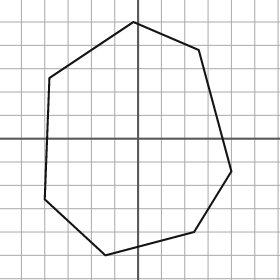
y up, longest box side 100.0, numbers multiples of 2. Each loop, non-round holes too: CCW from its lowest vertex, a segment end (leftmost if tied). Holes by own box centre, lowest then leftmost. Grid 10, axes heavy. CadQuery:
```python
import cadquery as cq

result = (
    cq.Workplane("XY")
    .moveTo(-14.0, -50.0)
    .lineTo(24.0, -40.0)
    .lineTo(40.0, -14.0)
    .lineTo(26.0, 38.0)
    .lineTo(-2.0, 50.0)
    .lineTo(-38.0, 26.0)
    .lineTo(-40.0, -26.0)
    .close()
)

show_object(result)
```